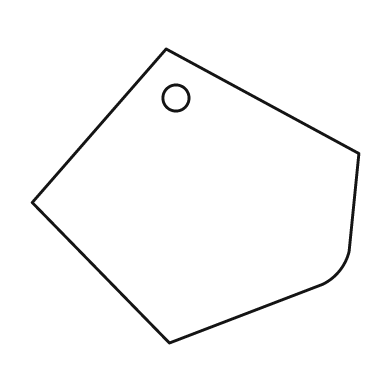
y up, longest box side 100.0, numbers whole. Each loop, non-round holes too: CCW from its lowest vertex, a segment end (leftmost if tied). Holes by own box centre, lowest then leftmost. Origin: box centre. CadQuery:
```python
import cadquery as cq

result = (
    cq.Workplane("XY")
    .moveTo(-8.0, -45.0)
    .lineTo(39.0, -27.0)
    .threePointArc((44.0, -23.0), (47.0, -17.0))
    .lineTo(50.0, 13.0)
    .lineTo(-9.0, 45.0)
    .lineTo(-50.0, -2.0)
    .close()
    .moveTo(-6.0, 30.0)
    .circle(4.0)
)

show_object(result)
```